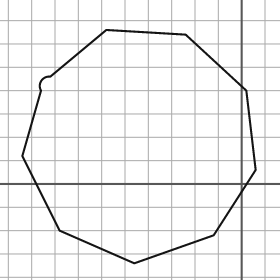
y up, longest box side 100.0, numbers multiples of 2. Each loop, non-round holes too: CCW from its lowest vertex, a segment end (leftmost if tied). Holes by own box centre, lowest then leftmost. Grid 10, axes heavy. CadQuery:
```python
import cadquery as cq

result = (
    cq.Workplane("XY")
    .moveTo(-46.0, -34.0)
    .lineTo(-12.0, -22.0)
    .lineTo(6.0, 6.0)
    .lineTo(2.0, 40.0)
    .lineTo(-24.0, 64.0)
    .lineTo(-58.0, 66.0)
    .lineTo(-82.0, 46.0)
    .threePointArc((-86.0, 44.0), (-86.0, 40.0))
    .lineTo(-94.0, 12.0)
    .lineTo(-78.0, -20.0)
    .close()
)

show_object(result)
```